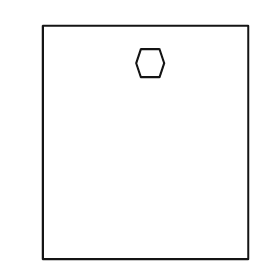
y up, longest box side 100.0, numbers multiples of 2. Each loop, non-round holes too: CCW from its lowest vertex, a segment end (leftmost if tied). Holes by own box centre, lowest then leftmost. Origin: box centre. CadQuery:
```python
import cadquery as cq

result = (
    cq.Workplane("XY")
    .moveTo(-44.0, -50.0)
    .lineTo(44.0, -50.0)
    .lineTo(44.0, 50.0)
    .lineTo(-44.0, 50.0)
    .close()
    .moveTo(-2.0, 28.0)
    .lineTo(6.0, 28.0)
    .lineTo(8.0, 34.0)
    .lineTo(6.0, 40.0)
    .lineTo(-2.0, 40.0)
    .lineTo(-4.0, 34.0)
    .close()
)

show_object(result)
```